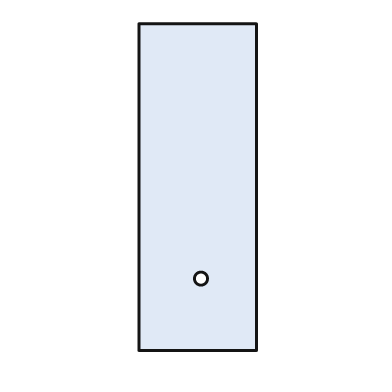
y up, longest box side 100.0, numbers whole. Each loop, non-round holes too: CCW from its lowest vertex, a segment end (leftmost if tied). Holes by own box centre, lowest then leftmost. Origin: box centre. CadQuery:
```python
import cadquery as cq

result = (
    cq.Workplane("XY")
    .moveTo(-18.0, -50.0)
    .lineTo(18.0, -50.0)
    .lineTo(18.0, 50.0)
    .lineTo(-18.0, 50.0)
    .close()
    .moveTo(1.0, -28.0)
    .circle(2.0)
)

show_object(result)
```